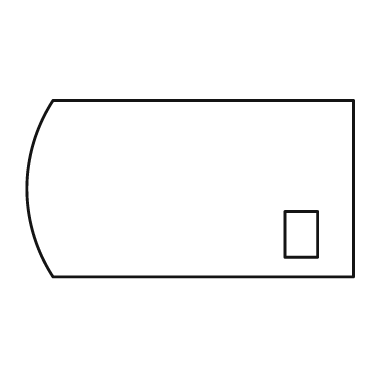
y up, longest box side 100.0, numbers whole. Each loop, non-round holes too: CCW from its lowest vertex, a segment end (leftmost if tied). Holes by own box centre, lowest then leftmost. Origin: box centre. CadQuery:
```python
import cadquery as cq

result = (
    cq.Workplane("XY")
    .moveTo(-42.0, -27.0)
    .lineTo(50.0, -27.0)
    .lineTo(50.0, 27.0)
    .lineTo(-42.0, 27.0)
    .threePointArc((-50.0, 0.0), (-42.0, -27.0))
    .close()
    .moveTo(29.0, -21.0)
    .lineTo(39.0, -21.0)
    .lineTo(39.0, -7.0)
    .lineTo(29.0, -7.0)
    .close()
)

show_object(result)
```